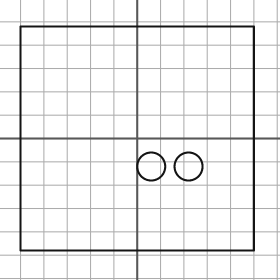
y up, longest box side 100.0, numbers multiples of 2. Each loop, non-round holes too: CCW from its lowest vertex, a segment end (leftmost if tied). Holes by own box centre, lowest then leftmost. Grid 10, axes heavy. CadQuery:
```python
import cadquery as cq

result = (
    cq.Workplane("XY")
    .moveTo(-50.0, -48.0)
    .lineTo(50.0, -48.0)
    .lineTo(50.0, 48.0)
    .lineTo(-50.0, 48.0)
    .close()
    .moveTo(6.0, -12.0)
    .circle(6.0)
    .moveTo(22.0, -12.0)
    .circle(6.0)
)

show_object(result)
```